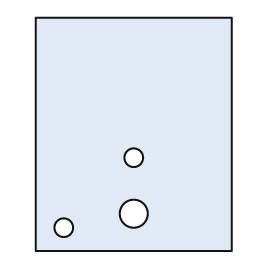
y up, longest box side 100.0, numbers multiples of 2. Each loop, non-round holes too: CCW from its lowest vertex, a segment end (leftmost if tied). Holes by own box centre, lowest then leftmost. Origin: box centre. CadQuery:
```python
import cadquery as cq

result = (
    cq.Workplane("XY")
    .moveTo(-42.0, -50.0)
    .lineTo(42.0, -50.0)
    .lineTo(42.0, 50.0)
    .lineTo(-42.0, 50.0)
    .close()
    .moveTo(-30.0, -40.0)
    .circle(4.0)
    .moveTo(0.0, -34.0)
    .circle(6.0)
    .moveTo(0.0, -10.0)
    .circle(4.0)
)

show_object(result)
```